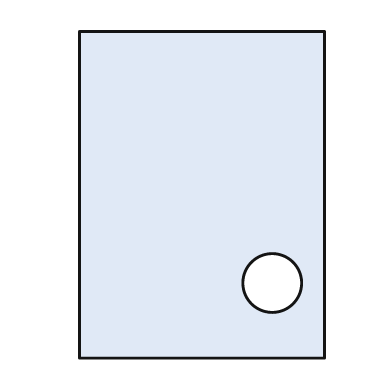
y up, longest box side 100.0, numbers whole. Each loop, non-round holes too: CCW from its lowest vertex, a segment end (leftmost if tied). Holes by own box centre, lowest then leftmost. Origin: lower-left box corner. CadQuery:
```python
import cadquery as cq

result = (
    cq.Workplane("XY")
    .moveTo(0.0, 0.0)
    .lineTo(75.0, 0.0)
    .lineTo(75.0, 100.0)
    .lineTo(0.0, 100.0)
    .close()
    .moveTo(59.0, 23.0)
    .circle(9.0)
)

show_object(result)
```